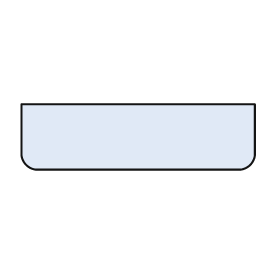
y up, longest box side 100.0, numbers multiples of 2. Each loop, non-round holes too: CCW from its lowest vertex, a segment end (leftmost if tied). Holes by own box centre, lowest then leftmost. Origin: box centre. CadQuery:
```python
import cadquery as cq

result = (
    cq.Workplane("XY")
    .moveTo(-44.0, -14.0)
    .lineTo(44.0, -14.0)
    .threePointArc((48.0, -12.0), (50.0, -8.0))
    .lineTo(50.0, 14.0)
    .lineTo(-50.0, 14.0)
    .lineTo(-50.0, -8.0)
    .threePointArc((-48.0, -12.0), (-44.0, -14.0))
    .close()
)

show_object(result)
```